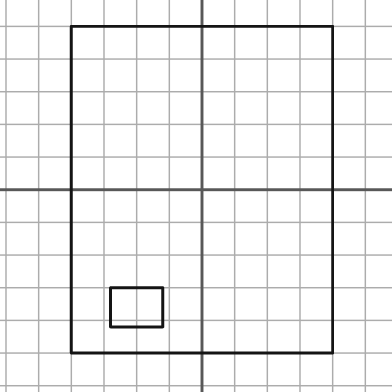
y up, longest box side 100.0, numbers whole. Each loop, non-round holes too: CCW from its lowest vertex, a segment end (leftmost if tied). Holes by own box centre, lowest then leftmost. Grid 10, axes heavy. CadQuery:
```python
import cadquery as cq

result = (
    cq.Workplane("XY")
    .moveTo(-40.0, -50.0)
    .lineTo(40.0, -50.0)
    .lineTo(40.0, 50.0)
    .lineTo(-40.0, 50.0)
    .close()
    .moveTo(-28.0, -42.0)
    .lineTo(-12.0, -42.0)
    .lineTo(-12.0, -30.0)
    .lineTo(-28.0, -30.0)
    .close()
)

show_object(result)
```